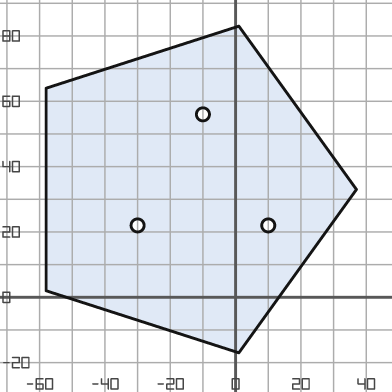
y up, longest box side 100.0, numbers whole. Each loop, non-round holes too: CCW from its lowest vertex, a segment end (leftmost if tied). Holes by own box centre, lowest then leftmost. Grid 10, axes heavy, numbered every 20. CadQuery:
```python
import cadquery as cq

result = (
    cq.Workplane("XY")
    .moveTo(1.0, -17.0)
    .lineTo(37.0, 33.0)
    .lineTo(1.0, 83.0)
    .lineTo(-58.0, 64.0)
    .lineTo(-58.0, 2.0)
    .close()
    .moveTo(-30.0, 22.0)
    .circle(2.0)
    .moveTo(10.0, 22.0)
    .circle(2.0)
    .moveTo(-10.0, 56.0)
    .circle(2.0)
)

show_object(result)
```